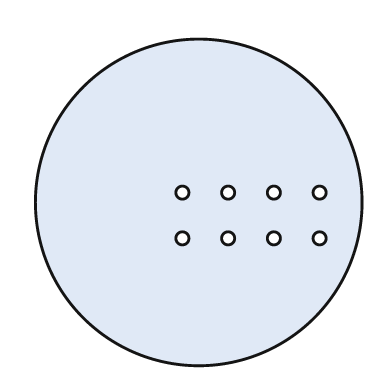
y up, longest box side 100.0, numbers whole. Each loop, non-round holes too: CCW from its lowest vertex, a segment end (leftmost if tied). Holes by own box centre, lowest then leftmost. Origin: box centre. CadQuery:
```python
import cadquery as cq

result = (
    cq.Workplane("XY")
    .moveTo(0.0, 0.0)
    .circle(50.0)
    .moveTo(-5.0, -11.0)
    .circle(2.0)
    .moveTo(9.0, -11.0)
    .circle(2.0)
    .moveTo(23.0, -11.0)
    .circle(2.0)
    .moveTo(37.0, -11.0)
    .circle(2.0)
    .moveTo(-5.0, 3.0)
    .circle(2.0)
    .moveTo(9.0, 3.0)
    .circle(2.0)
    .moveTo(23.0, 3.0)
    .circle(2.0)
    .moveTo(37.0, 3.0)
    .circle(2.0)
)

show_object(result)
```